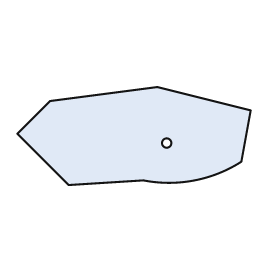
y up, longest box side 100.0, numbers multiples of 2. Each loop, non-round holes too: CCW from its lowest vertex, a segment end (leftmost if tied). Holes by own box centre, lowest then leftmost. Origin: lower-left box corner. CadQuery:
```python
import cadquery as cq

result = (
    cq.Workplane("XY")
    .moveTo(22.0, 0.0)
    .lineTo(54.0, 2.0)
    .threePointArc((76.0, 2.0), (96.0, 10.0))
    .lineTo(100.0, 32.0)
    .lineTo(60.0, 42.0)
    .lineTo(14.0, 36.0)
    .lineTo(0.0, 22.0)
    .close()
    .moveTo(64.0, 18.0)
    .circle(2.0)
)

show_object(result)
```